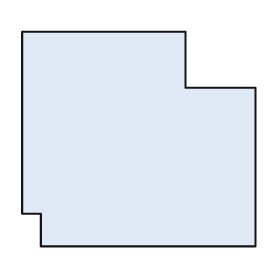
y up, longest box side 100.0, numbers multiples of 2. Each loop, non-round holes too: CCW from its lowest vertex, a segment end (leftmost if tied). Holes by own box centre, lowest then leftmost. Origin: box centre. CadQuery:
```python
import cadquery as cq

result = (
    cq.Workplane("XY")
    .moveTo(-42.0, -46.0)
    .lineTo(50.0, -46.0)
    .lineTo(50.0, 22.0)
    .lineTo(20.0, 22.0)
    .lineTo(20.0, 46.0)
    .lineTo(-50.0, 46.0)
    .lineTo(-50.0, -32.0)
    .lineTo(-42.0, -32.0)
    .close()
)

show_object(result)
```